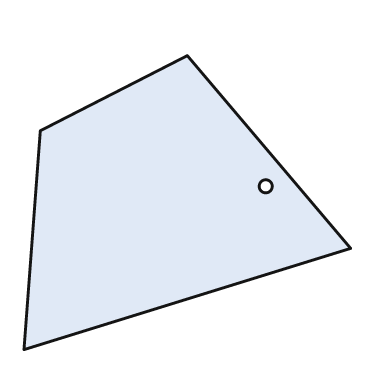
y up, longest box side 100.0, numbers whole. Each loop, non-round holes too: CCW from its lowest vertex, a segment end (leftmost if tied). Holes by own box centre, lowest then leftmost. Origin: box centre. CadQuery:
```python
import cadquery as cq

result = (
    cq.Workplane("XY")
    .moveTo(-50.0, -45.0)
    .lineTo(50.0, -14.0)
    .lineTo(0.0, 45.0)
    .lineTo(-45.0, 22.0)
    .close()
    .moveTo(24.0, 5.0)
    .circle(2.0)
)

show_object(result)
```